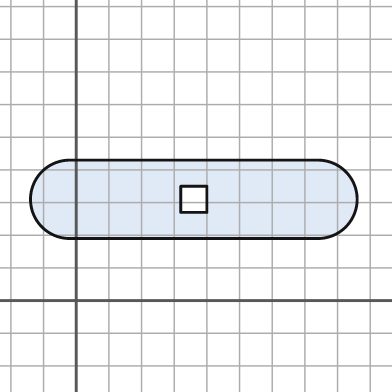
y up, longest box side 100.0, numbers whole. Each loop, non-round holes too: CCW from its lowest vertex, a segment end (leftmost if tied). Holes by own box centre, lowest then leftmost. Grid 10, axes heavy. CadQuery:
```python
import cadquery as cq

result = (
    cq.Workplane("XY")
    .moveTo(-2.0, 19.0)
    .lineTo(74.0, 19.0)
    .threePointArc((86.0, 31.0), (74.0, 43.0))
    .lineTo(-2.0, 43.0)
    .threePointArc((-14.0, 31.0), (-2.0, 19.0))
    .close()
    .moveTo(32.0, 27.0)
    .lineTo(40.0, 27.0)
    .lineTo(40.0, 35.0)
    .lineTo(32.0, 35.0)
    .close()
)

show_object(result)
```